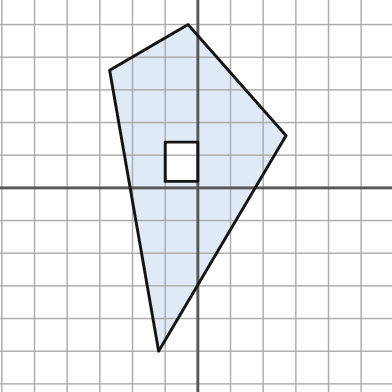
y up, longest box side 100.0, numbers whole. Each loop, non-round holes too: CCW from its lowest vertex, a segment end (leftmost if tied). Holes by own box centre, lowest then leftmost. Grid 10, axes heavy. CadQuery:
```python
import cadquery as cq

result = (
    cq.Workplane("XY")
    .moveTo(-12.0, -50.0)
    .lineTo(27.0, 16.0)
    .lineTo(-3.0, 50.0)
    .lineTo(-27.0, 36.0)
    .close()
    .moveTo(-10.0, 2.0)
    .lineTo(0.0, 2.0)
    .lineTo(0.0, 14.0)
    .lineTo(-10.0, 14.0)
    .close()
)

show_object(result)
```